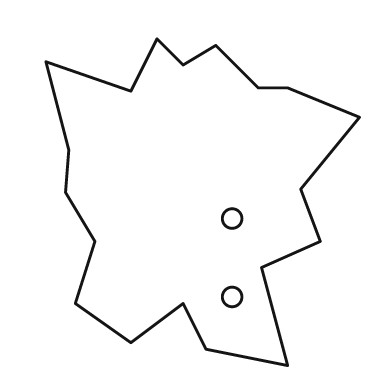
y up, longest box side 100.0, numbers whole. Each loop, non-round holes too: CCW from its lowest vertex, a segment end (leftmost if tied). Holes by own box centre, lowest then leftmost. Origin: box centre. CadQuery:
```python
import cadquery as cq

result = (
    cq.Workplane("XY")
    .moveTo(26.0, -50.0)
    .lineTo(18.0, -20.0)
    .lineTo(36.0, -12.0)
    .lineTo(30.0, 4.0)
    .lineTo(48.0, 26.0)
    .lineTo(26.0, 35.0)
    .lineTo(17.0, 35.0)
    .lineTo(4.0, 48.0)
    .lineTo(-6.0, 42.0)
    .lineTo(-14.0, 50.0)
    .lineTo(-22.0, 34.0)
    .lineTo(-48.0, 43.0)
    .lineTo(-41.0, 16.0)
    .lineTo(-42.0, 3.0)
    .lineTo(-33.0, -12.0)
    .lineTo(-39.0, -31.0)
    .lineTo(-22.0, -43.0)
    .lineTo(-6.0, -31.0)
    .lineTo(1.0, -45.0)
    .close()
    .moveTo(9.0, -29.0)
    .circle(3.0)
    .moveTo(9.0, -5.0)
    .circle(3.0)
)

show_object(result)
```